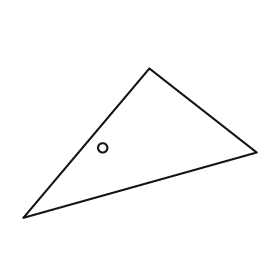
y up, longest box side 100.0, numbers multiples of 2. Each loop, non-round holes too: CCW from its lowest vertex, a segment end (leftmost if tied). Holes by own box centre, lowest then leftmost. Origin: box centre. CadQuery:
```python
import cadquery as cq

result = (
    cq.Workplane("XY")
    .moveTo(-50.0, -32.0)
    .lineTo(50.0, -4.0)
    .lineTo(4.0, 32.0)
    .close()
    .moveTo(-16.0, -2.0)
    .circle(2.0)
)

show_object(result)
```